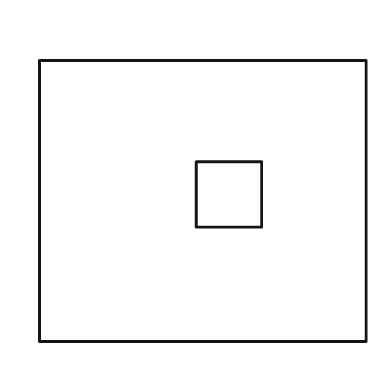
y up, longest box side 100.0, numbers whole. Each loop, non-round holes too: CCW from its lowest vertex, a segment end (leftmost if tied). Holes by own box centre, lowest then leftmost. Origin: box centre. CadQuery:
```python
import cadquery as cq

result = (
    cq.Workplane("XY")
    .moveTo(-50.0, -43.0)
    .lineTo(50.0, -43.0)
    .lineTo(50.0, 43.0)
    .lineTo(-50.0, 43.0)
    .close()
    .moveTo(-2.0, -8.0)
    .lineTo(18.0, -8.0)
    .lineTo(18.0, 12.0)
    .lineTo(-2.0, 12.0)
    .close()
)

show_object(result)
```